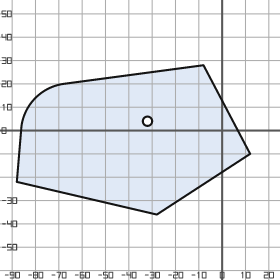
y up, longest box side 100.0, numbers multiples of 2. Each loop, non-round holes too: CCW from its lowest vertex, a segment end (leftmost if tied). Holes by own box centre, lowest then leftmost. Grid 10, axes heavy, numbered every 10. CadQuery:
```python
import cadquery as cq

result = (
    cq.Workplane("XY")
    .moveTo(-28.0, -36.0)
    .lineTo(12.0, -10.0)
    .lineTo(-8.0, 28.0)
    .lineTo(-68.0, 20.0)
    .threePointArc((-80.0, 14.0), (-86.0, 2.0))
    .lineTo(-88.0, -22.0)
    .close()
    .moveTo(-32.0, 4.0)
    .circle(2.0)
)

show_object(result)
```